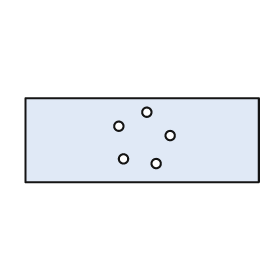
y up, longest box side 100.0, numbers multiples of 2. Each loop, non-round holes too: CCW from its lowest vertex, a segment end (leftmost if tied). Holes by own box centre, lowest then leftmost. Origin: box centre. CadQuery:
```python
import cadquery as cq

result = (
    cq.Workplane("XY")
    .moveTo(-50.0, -18.0)
    .lineTo(50.0, -18.0)
    .lineTo(50.0, 18.0)
    .lineTo(-50.0, 18.0)
    .close()
    .moveTo(6.0, -10.0)
    .circle(2.0)
    .moveTo(-8.0, -8.0)
    .circle(2.0)
    .moveTo(12.0, 2.0)
    .circle(2.0)
    .moveTo(-10.0, 6.0)
    .circle(2.0)
    .moveTo(2.0, 12.0)
    .circle(2.0)
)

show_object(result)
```